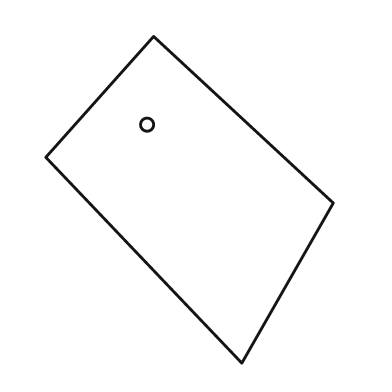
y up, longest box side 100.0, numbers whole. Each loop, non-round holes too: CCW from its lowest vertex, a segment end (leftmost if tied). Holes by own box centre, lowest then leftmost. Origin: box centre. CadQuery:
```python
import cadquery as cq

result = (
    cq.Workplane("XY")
    .moveTo(16.0, -50.0)
    .lineTo(44.0, -1.0)
    .lineTo(-11.0, 50.0)
    .lineTo(-44.0, 13.0)
    .close()
    .moveTo(-13.0, 23.0)
    .circle(2.0)
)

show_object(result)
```